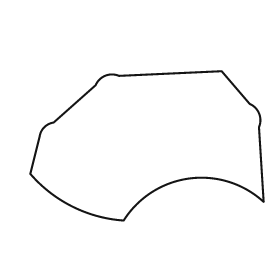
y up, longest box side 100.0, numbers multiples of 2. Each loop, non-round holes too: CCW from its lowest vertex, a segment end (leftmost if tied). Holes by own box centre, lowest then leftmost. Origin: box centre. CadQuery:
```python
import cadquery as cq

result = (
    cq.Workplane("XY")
    .moveTo(-10.0, -32.0)
    .threePointArc((18.0, -14.0), (50.0, -24.0))
    .lineTo(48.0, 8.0)
    .threePointArc((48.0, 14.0), (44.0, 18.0))
    .lineTo(32.0, 32.0)
    .lineTo(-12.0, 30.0)
    .threePointArc((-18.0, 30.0), (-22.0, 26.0))
    .lineTo(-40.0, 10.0)
    .threePointArc((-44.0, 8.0), (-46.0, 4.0))
    .lineTo(-50.0, -12.0)
    .threePointArc((-32.0, -26.0), (-10.0, -32.0))
    .close()
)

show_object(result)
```